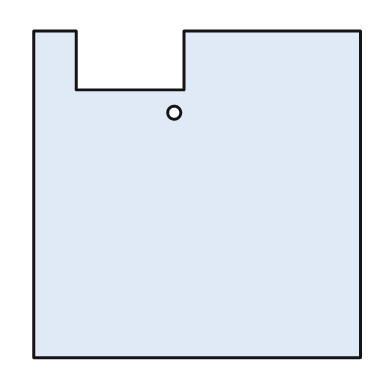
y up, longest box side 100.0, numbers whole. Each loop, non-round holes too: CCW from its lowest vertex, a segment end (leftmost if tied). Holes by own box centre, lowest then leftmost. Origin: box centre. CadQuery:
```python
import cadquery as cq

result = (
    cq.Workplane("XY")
    .moveTo(-50.0, -50.0)
    .lineTo(50.0, -50.0)
    .lineTo(50.0, 50.0)
    .lineTo(-4.0, 50.0)
    .lineTo(-4.0, 32.0)
    .lineTo(-37.0, 32.0)
    .lineTo(-37.0, 50.0)
    .lineTo(-50.0, 50.0)
    .close()
    .moveTo(-7.0, 25.0)
    .circle(2.0)
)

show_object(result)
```